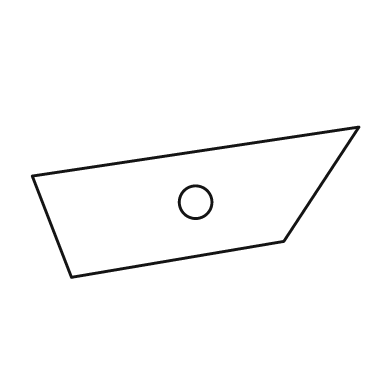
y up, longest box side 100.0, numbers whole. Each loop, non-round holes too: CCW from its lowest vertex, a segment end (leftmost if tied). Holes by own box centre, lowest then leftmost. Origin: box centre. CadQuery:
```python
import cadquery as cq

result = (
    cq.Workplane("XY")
    .moveTo(-38.0, -23.0)
    .lineTo(27.0, -12.0)
    .lineTo(50.0, 23.0)
    .lineTo(-50.0, 8.0)
    .close()
    .moveTo(0.0, 0.0)
    .circle(5.0)
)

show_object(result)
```